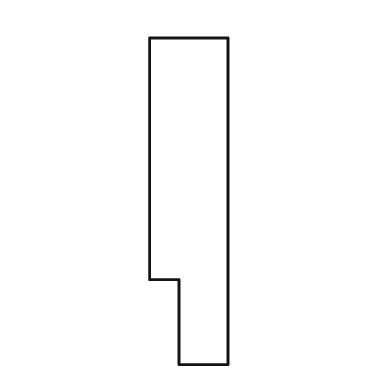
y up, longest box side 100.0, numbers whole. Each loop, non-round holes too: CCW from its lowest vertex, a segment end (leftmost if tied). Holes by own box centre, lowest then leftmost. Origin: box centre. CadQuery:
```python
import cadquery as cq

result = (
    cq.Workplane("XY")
    .moveTo(-3.0, -50.0)
    .lineTo(12.0, -50.0)
    .lineTo(12.0, 50.0)
    .lineTo(-12.0, 50.0)
    .lineTo(-12.0, -24.0)
    .lineTo(-3.0, -24.0)
    .close()
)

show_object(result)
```